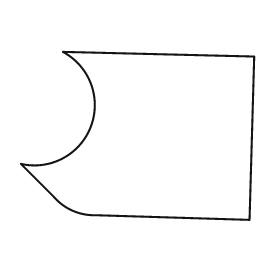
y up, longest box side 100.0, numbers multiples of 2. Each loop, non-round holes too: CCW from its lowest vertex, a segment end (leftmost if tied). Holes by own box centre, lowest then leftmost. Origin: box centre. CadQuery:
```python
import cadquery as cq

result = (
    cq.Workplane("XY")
    .moveTo(48.0, -36.0)
    .lineTo(50.0, 34.0)
    .lineTo(-32.0, 36.0)
    .threePointArc((-20.0, 4.0), (-50.0, -12.0))
    .lineTo(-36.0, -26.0)
    .threePointArc((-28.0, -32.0), (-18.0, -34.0))
    .close()
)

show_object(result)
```